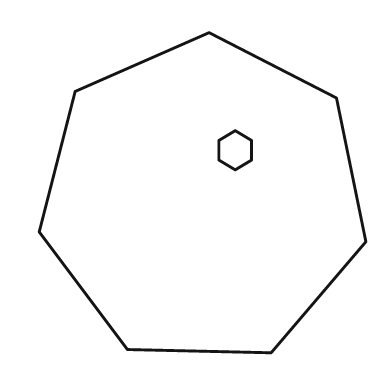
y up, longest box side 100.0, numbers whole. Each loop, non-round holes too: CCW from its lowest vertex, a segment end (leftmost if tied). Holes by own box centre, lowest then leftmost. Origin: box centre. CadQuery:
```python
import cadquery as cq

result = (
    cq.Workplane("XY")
    .moveTo(21.0, -49.0)
    .lineTo(50.0, -15.0)
    .lineTo(41.0, 29.0)
    .lineTo(2.0, 49.0)
    .lineTo(-39.0, 31.0)
    .lineTo(-50.0, -12.0)
    .lineTo(-23.0, -48.0)
    .close()
    .moveTo(10.0, 7.0)
    .lineTo(15.0, 10.0)
    .lineTo(15.0, 16.0)
    .lineTo(10.0, 19.0)
    .lineTo(5.0, 16.0)
    .lineTo(5.0, 10.0)
    .close()
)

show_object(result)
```